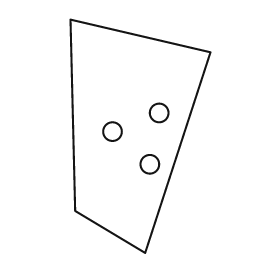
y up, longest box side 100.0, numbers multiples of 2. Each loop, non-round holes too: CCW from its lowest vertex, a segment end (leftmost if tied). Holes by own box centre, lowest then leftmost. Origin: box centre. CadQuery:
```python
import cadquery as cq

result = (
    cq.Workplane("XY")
    .moveTo(2.0, -50.0)
    .lineTo(30.0, 36.0)
    .lineTo(-30.0, 50.0)
    .lineTo(-28.0, -32.0)
    .close()
    .moveTo(4.0, -12.0)
    .circle(4.0)
    .moveTo(-12.0, 2.0)
    .circle(4.0)
    .moveTo(8.0, 10.0)
    .circle(4.0)
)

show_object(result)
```